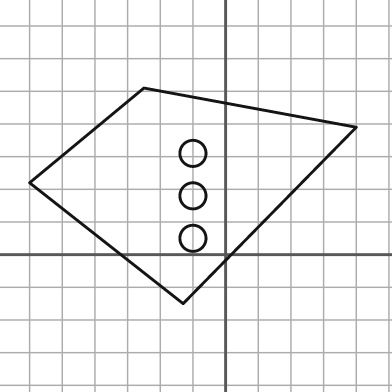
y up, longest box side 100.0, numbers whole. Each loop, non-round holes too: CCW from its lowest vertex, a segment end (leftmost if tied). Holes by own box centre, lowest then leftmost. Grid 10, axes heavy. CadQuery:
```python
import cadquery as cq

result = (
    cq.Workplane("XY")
    .moveTo(-13.0, -15.0)
    .lineTo(40.0, 39.0)
    .lineTo(-25.0, 51.0)
    .lineTo(-60.0, 22.0)
    .close()
    .moveTo(-10.0, 5.0)
    .circle(4.0)
    .moveTo(-10.0, 18.0)
    .circle(4.0)
    .moveTo(-10.0, 31.0)
    .circle(4.0)
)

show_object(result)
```